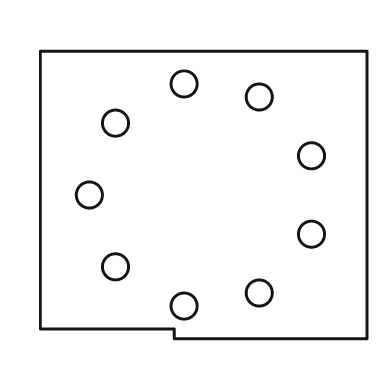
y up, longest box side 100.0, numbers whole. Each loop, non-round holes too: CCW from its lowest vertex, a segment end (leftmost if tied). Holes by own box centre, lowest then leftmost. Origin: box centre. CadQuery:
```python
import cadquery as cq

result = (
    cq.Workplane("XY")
    .moveTo(-9.0, -44.0)
    .lineTo(50.0, -44.0)
    .lineTo(50.0, 44.0)
    .lineTo(-50.0, 44.0)
    .lineTo(-50.0, -41.0)
    .lineTo(-9.0, -41.0)
    .close()
    .moveTo(-6.0, -34.0)
    .circle(4.0)
    .moveTo(17.0, -30.0)
    .circle(4.0)
    .moveTo(-27.0, -22.0)
    .circle(4.0)
    .moveTo(33.0, -12.0)
    .circle(4.0)
    .moveTo(-35.0, 0.0)
    .circle(4.0)
    .moveTo(33.0, 12.0)
    .circle(4.0)
    .moveTo(-27.0, 22.0)
    .circle(4.0)
    .moveTo(17.0, 30.0)
    .circle(4.0)
    .moveTo(-6.0, 34.0)
    .circle(4.0)
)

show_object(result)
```